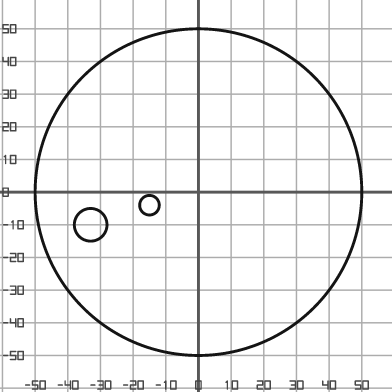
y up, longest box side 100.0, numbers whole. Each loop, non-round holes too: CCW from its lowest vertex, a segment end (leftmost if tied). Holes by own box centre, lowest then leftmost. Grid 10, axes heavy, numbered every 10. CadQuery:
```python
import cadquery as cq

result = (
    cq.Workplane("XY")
    .moveTo(0.0, 0.0)
    .circle(50.0)
    .moveTo(-33.0, -10.0)
    .circle(5.0)
    .moveTo(-15.0, -4.0)
    .circle(3.0)
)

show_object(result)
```